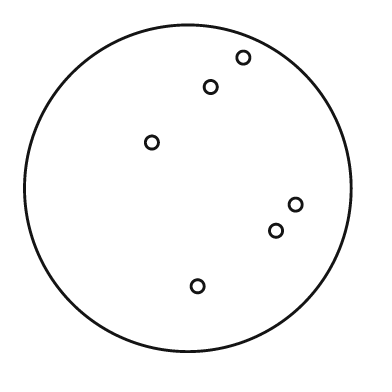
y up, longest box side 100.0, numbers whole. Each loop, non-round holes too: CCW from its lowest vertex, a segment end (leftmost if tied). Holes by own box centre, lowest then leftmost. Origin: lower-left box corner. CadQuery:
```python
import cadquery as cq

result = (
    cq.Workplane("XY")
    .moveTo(50.0, 50.0)
    .circle(50.0)
    .moveTo(53.0, 20.0)
    .circle(2.0)
    .moveTo(77.0, 37.0)
    .circle(2.0)
    .moveTo(83.0, 45.0)
    .circle(2.0)
    .moveTo(39.0, 64.0)
    .circle(2.0)
    .moveTo(57.0, 81.0)
    .circle(2.0)
    .moveTo(67.0, 90.0)
    .circle(2.0)
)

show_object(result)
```